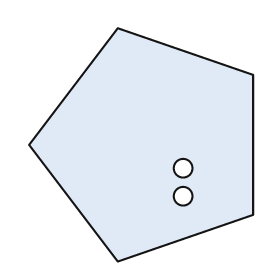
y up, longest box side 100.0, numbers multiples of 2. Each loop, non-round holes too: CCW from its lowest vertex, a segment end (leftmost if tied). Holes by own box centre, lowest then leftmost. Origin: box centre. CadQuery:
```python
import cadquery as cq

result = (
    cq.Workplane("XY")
    .moveTo(-10.0, -50.0)
    .lineTo(48.0, -30.0)
    .lineTo(48.0, 30.0)
    .lineTo(-10.0, 50.0)
    .lineTo(-48.0, 0.0)
    .close()
    .moveTo(18.0, -22.0)
    .circle(4.0)
    .moveTo(18.0, -10.0)
    .circle(4.0)
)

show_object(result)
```